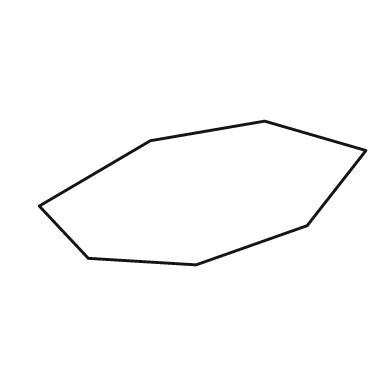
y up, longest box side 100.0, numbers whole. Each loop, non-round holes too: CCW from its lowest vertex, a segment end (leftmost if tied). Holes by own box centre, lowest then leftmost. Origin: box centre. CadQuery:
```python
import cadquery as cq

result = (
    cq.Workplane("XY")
    .moveTo(-2.0, -22.0)
    .lineTo(32.0, -10.0)
    .lineTo(50.0, 13.0)
    .lineTo(19.0, 22.0)
    .lineTo(-16.0, 16.0)
    .lineTo(-50.0, -4.0)
    .lineTo(-35.0, -20.0)
    .close()
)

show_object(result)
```